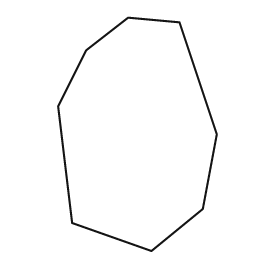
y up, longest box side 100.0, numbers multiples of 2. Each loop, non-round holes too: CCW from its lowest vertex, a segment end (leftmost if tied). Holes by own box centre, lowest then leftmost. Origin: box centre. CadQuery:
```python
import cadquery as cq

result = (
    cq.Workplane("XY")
    .moveTo(6.0, -50.0)
    .lineTo(28.0, -32.0)
    .lineTo(34.0, 0.0)
    .lineTo(18.0, 48.0)
    .lineTo(-4.0, 50.0)
    .lineTo(-22.0, 36.0)
    .lineTo(-34.0, 12.0)
    .lineTo(-28.0, -38.0)
    .close()
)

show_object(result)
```